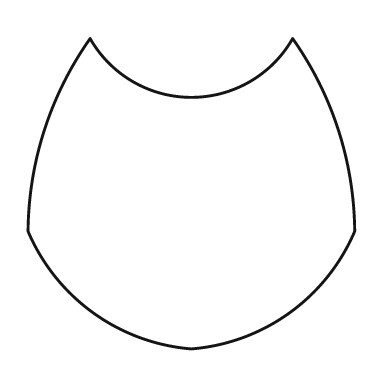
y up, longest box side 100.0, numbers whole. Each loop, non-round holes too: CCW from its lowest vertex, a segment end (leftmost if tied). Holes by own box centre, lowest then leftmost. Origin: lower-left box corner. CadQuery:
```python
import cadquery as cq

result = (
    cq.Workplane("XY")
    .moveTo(50.0, 0.0)
    .threePointArc((80.0, 11.0), (100.0, 36.0))
    .threePointArc((95.0, 67.0), (81.0, 95.0))
    .threePointArc((50.0, 77.0), (19.0, 95.0))
    .threePointArc((5.0, 67.0), (0.0, 36.0))
    .threePointArc((20.0, 11.0), (50.0, 0.0))
    .close()
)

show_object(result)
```